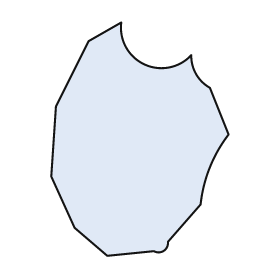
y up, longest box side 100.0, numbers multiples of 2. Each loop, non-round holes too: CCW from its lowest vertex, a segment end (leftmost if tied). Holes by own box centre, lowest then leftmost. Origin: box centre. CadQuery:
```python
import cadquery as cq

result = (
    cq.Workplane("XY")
    .moveTo(-14.0, -50.0)
    .lineTo(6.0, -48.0)
    .threePointArc((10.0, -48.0), (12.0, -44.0))
    .lineTo(26.0, -28.0)
    .threePointArc((30.0, -12.0), (38.0, 2.0))
    .lineTo(30.0, 22.0)
    .threePointArc((24.0, 28.0), (22.0, 36.0))
    .threePointArc((2.0, 32.0), (-8.0, 50.0))
    .lineTo(-22.0, 42.0)
    .lineTo(-36.0, 14.0)
    .lineTo(-38.0, -16.0)
    .lineTo(-28.0, -38.0)
    .close()
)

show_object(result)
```